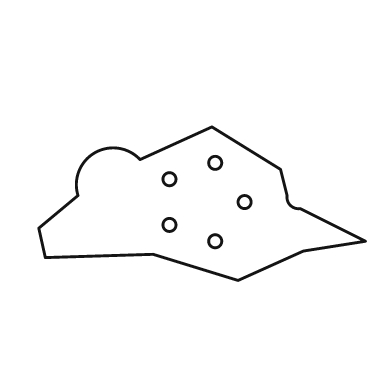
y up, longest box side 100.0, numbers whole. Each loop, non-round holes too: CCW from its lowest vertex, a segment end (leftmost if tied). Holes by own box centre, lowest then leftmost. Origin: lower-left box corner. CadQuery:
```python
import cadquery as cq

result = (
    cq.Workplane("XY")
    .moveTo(61.0, 0.0)
    .lineTo(81.0, 9.0)
    .lineTo(100.0, 12.0)
    .lineTo(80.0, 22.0)
    .threePointArc((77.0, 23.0), (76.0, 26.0))
    .lineTo(74.0, 34.0)
    .lineTo(53.0, 47.0)
    .lineTo(31.0, 37.0)
    .threePointArc((17.0, 39.0), (12.0, 26.0))
    .lineTo(0.0, 16.0)
    .lineTo(2.0, 7.0)
    .lineTo(35.0, 8.0)
    .close()
    .moveTo(54.0, 12.0)
    .circle(2.0)
    .moveTo(40.0, 17.0)
    .circle(2.0)
    .moveTo(63.0, 24.0)
    .circle(2.0)
    .moveTo(40.0, 31.0)
    .circle(2.0)
    .moveTo(54.0, 36.0)
    .circle(2.0)
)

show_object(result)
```